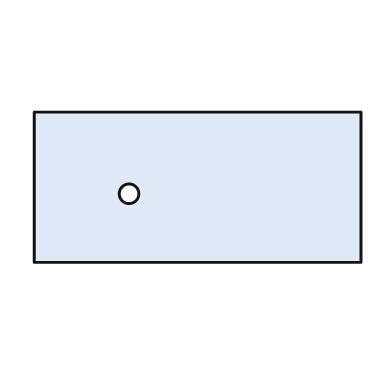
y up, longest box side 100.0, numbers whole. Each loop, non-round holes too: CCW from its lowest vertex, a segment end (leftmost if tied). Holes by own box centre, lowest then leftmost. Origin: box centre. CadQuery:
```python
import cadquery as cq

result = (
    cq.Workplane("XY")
    .moveTo(-50.0, -23.0)
    .lineTo(50.0, -23.0)
    .lineTo(50.0, 23.0)
    .lineTo(-50.0, 23.0)
    .close()
    .moveTo(-21.0, -2.0)
    .circle(3.0)
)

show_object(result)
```